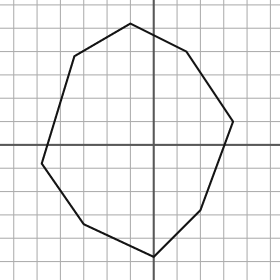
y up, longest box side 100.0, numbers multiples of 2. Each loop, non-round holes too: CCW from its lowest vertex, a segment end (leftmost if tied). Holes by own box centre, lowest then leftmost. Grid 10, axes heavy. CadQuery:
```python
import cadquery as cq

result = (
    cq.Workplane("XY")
    .moveTo(0.0, -48.0)
    .lineTo(20.0, -28.0)
    .lineTo(34.0, 10.0)
    .lineTo(14.0, 40.0)
    .lineTo(-10.0, 52.0)
    .lineTo(-34.0, 38.0)
    .lineTo(-48.0, -8.0)
    .lineTo(-30.0, -34.0)
    .close()
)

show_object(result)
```